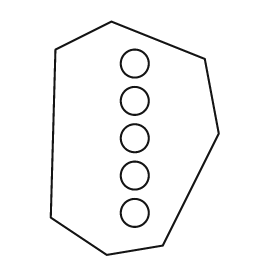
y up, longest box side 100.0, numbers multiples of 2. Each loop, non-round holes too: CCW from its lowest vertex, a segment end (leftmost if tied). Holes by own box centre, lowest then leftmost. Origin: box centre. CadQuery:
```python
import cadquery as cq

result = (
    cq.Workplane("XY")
    .moveTo(-12.0, -50.0)
    .lineTo(12.0, -46.0)
    .lineTo(36.0, 2.0)
    .lineTo(30.0, 34.0)
    .lineTo(-10.0, 50.0)
    .lineTo(-34.0, 38.0)
    .lineTo(-36.0, -34.0)
    .close()
    .moveTo(0.0, -32.0)
    .circle(6.0)
    .moveTo(0.0, -16.0)
    .circle(6.0)
    .moveTo(0.0, 0.0)
    .circle(6.0)
    .moveTo(0.0, 16.0)
    .circle(6.0)
    .moveTo(0.0, 32.0)
    .circle(6.0)
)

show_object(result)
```